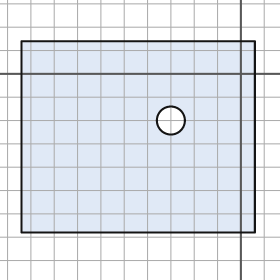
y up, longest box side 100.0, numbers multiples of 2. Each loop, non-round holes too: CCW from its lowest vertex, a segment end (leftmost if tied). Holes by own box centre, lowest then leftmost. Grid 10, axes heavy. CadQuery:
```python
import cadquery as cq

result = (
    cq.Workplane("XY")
    .moveTo(-94.0, -68.0)
    .lineTo(6.0, -68.0)
    .lineTo(6.0, 14.0)
    .lineTo(-94.0, 14.0)
    .close()
    .moveTo(-30.0, -20.0)
    .circle(6.0)
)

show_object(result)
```